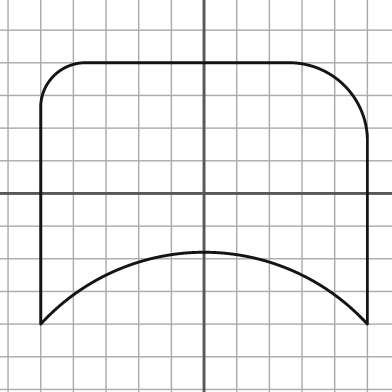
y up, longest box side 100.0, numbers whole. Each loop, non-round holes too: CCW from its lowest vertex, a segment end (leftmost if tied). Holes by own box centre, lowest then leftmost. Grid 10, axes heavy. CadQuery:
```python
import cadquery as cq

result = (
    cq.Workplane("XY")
    .moveTo(-50.0, -40.0)
    .threePointArc((0.0, -18.0), (50.0, -40.0))
    .lineTo(50.0, 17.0)
    .threePointArc((43.0, 33.0), (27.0, 40.0))
    .lineTo(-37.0, 40.0)
    .threePointArc((-46.0, 36.0), (-50.0, 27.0))
    .close()
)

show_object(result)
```